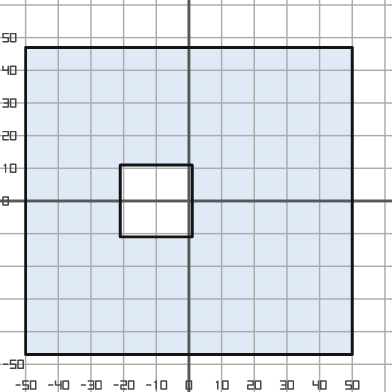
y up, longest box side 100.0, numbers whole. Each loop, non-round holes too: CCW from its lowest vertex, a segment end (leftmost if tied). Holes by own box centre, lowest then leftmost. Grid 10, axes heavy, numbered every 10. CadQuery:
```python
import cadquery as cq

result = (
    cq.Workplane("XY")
    .moveTo(-50.0, -47.0)
    .lineTo(50.0, -47.0)
    .lineTo(50.0, 47.0)
    .lineTo(-50.0, 47.0)
    .close()
    .moveTo(-21.0, -11.0)
    .lineTo(1.0, -11.0)
    .lineTo(1.0, 11.0)
    .lineTo(-21.0, 11.0)
    .close()
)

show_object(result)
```